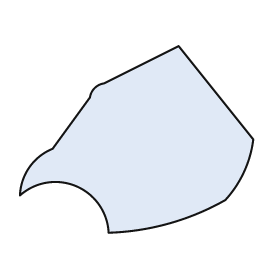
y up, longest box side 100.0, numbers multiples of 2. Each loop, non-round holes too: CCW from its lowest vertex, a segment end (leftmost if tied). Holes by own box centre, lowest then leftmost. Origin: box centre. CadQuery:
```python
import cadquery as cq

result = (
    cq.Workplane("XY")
    .moveTo(-12.0, -40.0)
    .threePointArc((14.0, -36.0), (38.0, -26.0))
    .threePointArc((46.0, -14.0), (50.0, 0.0))
    .lineTo(18.0, 40.0)
    .lineTo(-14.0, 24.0)
    .threePointArc((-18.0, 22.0), (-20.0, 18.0))
    .lineTo(-36.0, -4.0)
    .threePointArc((-46.0, -12.0), (-50.0, -24.0))
    .threePointArc((-26.0, -20.0), (-12.0, -40.0))
    .close()
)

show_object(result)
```